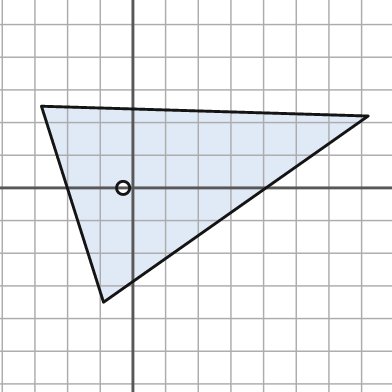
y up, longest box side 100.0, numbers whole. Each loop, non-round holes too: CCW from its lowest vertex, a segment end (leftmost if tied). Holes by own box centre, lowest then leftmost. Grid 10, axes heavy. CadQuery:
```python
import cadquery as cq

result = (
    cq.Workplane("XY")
    .moveTo(-9.0, -35.0)
    .lineTo(72.0, 22.0)
    .lineTo(-28.0, 25.0)
    .close()
    .moveTo(-3.0, 0.0)
    .circle(2.0)
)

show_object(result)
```